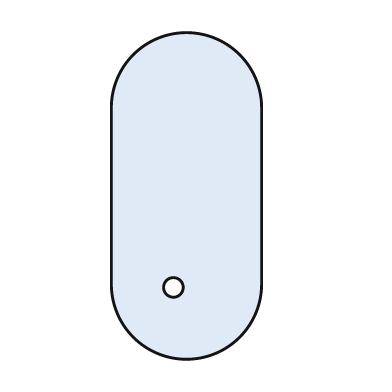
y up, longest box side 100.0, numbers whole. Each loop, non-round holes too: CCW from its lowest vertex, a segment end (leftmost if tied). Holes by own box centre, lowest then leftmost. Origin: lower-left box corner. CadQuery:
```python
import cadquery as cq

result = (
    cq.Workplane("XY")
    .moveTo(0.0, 23.0)
    .threePointArc((23.0, 0.0), (46.0, 23.0))
    .lineTo(46.0, 77.0)
    .threePointArc((23.0, 100.0), (0.0, 77.0))
    .close()
    .moveTo(19.0, 22.0)
    .circle(3.0)
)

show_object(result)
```